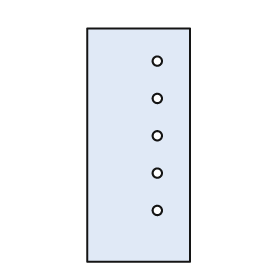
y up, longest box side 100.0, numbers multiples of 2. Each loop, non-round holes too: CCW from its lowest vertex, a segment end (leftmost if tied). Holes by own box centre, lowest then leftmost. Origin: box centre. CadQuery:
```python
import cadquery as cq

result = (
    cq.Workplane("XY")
    .moveTo(-22.0, -50.0)
    .lineTo(22.0, -50.0)
    .lineTo(22.0, 50.0)
    .lineTo(-22.0, 50.0)
    .close()
    .moveTo(8.0, -28.0)
    .circle(2.0)
    .moveTo(8.0, -12.0)
    .circle(2.0)
    .moveTo(8.0, 4.0)
    .circle(2.0)
    .moveTo(8.0, 20.0)
    .circle(2.0)
    .moveTo(8.0, 36.0)
    .circle(2.0)
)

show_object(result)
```